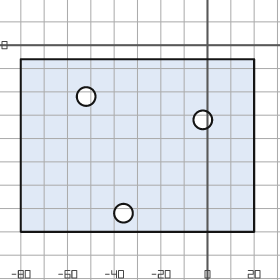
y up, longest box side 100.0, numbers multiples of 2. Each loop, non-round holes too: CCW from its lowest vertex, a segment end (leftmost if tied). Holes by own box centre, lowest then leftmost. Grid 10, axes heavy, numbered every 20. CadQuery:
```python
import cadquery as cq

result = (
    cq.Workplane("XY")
    .moveTo(-80.0, -80.0)
    .lineTo(20.0, -80.0)
    .lineTo(20.0, -6.0)
    .lineTo(-80.0, -6.0)
    .close()
    .moveTo(-36.0, -72.0)
    .circle(4.0)
    .moveTo(-2.0, -32.0)
    .circle(4.0)
    .moveTo(-52.0, -22.0)
    .circle(4.0)
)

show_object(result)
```